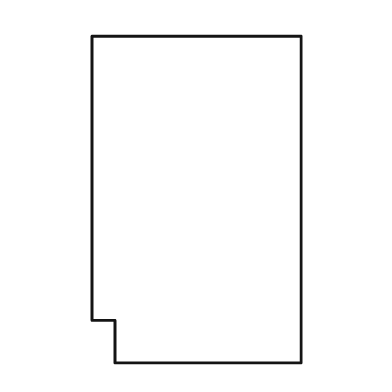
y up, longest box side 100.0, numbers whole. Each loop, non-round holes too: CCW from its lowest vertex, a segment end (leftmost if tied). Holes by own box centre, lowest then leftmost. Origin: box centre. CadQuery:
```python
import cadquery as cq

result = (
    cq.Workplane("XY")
    .moveTo(-25.0, -50.0)
    .lineTo(32.0, -50.0)
    .lineTo(32.0, 50.0)
    .lineTo(-32.0, 50.0)
    .lineTo(-32.0, -37.0)
    .lineTo(-25.0, -37.0)
    .close()
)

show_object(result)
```